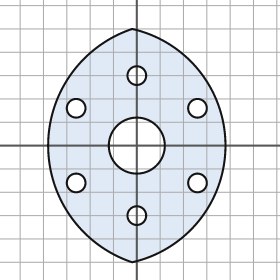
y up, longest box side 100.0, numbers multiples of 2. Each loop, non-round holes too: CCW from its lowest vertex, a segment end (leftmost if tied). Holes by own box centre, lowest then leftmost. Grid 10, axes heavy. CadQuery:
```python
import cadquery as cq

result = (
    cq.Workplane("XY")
    .moveTo(-2.0, -50.0)
    .threePointArc((38.0, 0.0), (-2.0, 50.0))
    .threePointArc((-38.0, 0.0), (-2.0, -50.0))
    .close()
    .moveTo(0.0, -30.0)
    .circle(4.0)
    .moveTo(-26.0, -16.0)
    .circle(4.0)
    .moveTo(26.0, -16.0)
    .circle(4.0)
    .moveTo(0.0, 0.0)
    .circle(12.0)
    .moveTo(-26.0, 16.0)
    .circle(4.0)
    .moveTo(26.0, 16.0)
    .circle(4.0)
    .moveTo(0.0, 30.0)
    .circle(4.0)
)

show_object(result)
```